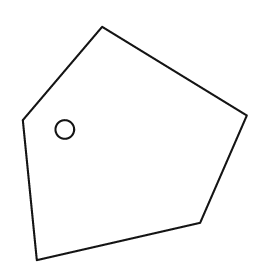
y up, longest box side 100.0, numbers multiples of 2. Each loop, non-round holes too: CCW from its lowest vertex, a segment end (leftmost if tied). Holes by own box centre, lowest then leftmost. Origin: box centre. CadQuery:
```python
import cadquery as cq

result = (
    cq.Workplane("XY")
    .moveTo(-42.0, -50.0)
    .lineTo(28.0, -34.0)
    .lineTo(48.0, 12.0)
    .lineTo(-14.0, 50.0)
    .lineTo(-48.0, 10.0)
    .close()
    .moveTo(-30.0, 6.0)
    .circle(4.0)
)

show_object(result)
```